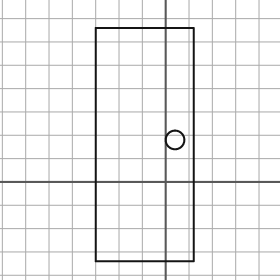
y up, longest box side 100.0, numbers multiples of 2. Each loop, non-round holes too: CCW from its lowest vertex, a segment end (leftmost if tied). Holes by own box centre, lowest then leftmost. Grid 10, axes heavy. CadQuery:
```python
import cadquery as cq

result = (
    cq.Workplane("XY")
    .moveTo(-30.0, -34.0)
    .lineTo(12.0, -34.0)
    .lineTo(12.0, 66.0)
    .lineTo(-30.0, 66.0)
    .close()
    .moveTo(4.0, 18.0)
    .circle(4.0)
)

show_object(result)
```